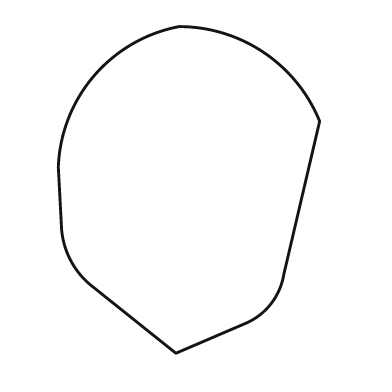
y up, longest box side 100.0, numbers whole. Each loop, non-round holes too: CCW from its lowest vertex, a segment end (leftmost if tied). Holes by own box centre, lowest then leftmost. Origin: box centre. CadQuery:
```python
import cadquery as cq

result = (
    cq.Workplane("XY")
    .moveTo(-4.0, -50.0)
    .lineTo(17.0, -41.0)
    .threePointArc((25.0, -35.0), (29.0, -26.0))
    .lineTo(40.0, 21.0)
    .threePointArc((23.0, 42.0), (-3.0, 50.0))
    .threePointArc((-29.0, 35.0), (-40.0, 7.0))
    .lineTo(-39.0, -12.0)
    .threePointArc((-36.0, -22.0), (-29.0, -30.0))
    .close()
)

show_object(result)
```